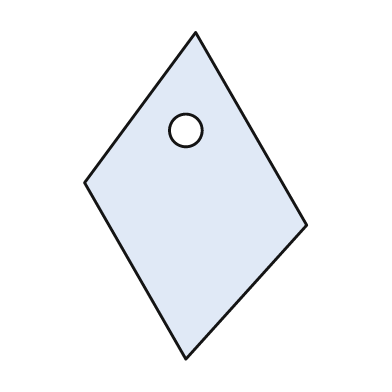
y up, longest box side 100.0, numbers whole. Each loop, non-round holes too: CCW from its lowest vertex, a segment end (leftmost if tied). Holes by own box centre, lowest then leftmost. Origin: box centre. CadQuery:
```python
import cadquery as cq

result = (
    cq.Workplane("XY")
    .moveTo(-3.0, -50.0)
    .lineTo(34.0, -9.0)
    .lineTo(0.0, 50.0)
    .lineTo(-34.0, 4.0)
    .close()
    .moveTo(-3.0, 20.0)
    .circle(5.0)
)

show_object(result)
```